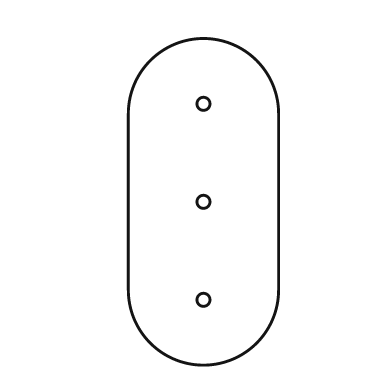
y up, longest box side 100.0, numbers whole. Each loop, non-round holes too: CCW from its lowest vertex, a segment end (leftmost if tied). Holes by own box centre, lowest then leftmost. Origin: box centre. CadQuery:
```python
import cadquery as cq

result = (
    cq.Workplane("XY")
    .moveTo(-23.0, -27.0)
    .threePointArc((0.0, -50.0), (23.0, -27.0))
    .lineTo(23.0, 27.0)
    .threePointArc((0.0, 50.0), (-23.0, 27.0))
    .close()
    .moveTo(0.0, -30.0)
    .circle(2.0)
    .moveTo(0.0, 0.0)
    .circle(2.0)
    .moveTo(0.0, 30.0)
    .circle(2.0)
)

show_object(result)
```